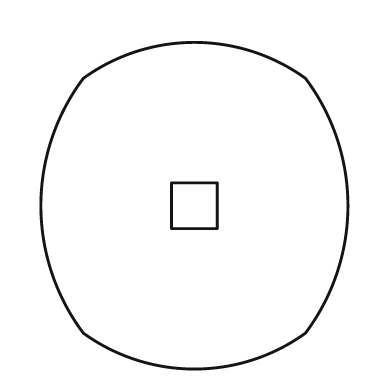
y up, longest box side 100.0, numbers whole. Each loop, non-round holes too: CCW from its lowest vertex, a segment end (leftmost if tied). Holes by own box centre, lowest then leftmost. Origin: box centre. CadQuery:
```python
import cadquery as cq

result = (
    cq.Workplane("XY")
    .moveTo(-34.0, -39.0)
    .threePointArc((0.0, -50.0), (34.0, -39.0))
    .threePointArc((47.0, 0.0), (34.0, 39.0))
    .threePointArc((0.0, 50.0), (-34.0, 39.0))
    .threePointArc((-47.0, 0.0), (-34.0, -39.0))
    .close()
    .moveTo(-7.0, -7.0)
    .lineTo(7.0, -7.0)
    .lineTo(7.0, 7.0)
    .lineTo(-7.0, 7.0)
    .close()
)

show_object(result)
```